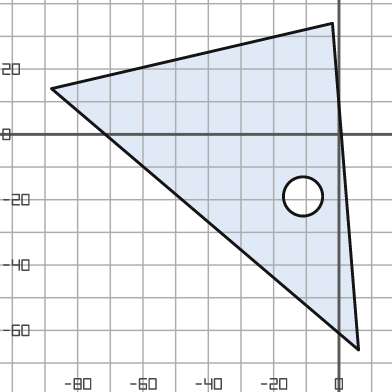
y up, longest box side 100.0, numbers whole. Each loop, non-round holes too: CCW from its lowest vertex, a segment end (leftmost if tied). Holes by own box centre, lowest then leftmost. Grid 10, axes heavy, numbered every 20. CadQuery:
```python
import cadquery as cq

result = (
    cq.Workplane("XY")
    .moveTo(6.0, -66.0)
    .lineTo(-2.0, 34.0)
    .lineTo(-88.0, 14.0)
    .close()
    .moveTo(-11.0, -19.0)
    .circle(6.0)
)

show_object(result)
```